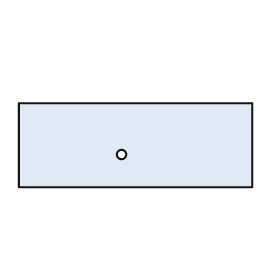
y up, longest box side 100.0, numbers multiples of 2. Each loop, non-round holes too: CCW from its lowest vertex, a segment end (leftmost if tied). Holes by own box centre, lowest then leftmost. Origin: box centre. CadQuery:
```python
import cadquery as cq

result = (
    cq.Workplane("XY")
    .moveTo(-50.0, -18.0)
    .lineTo(50.0, -18.0)
    .lineTo(50.0, 18.0)
    .lineTo(-50.0, 18.0)
    .close()
    .moveTo(-6.0, -4.0)
    .circle(2.0)
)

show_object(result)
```